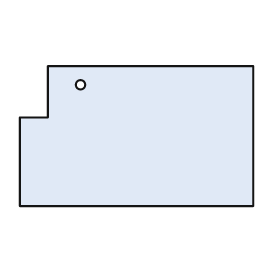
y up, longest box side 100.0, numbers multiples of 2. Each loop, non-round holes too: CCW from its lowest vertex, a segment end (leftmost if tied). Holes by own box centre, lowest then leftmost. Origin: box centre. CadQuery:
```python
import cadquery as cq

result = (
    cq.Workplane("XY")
    .moveTo(-50.0, -30.0)
    .lineTo(50.0, -30.0)
    .lineTo(50.0, 30.0)
    .lineTo(-38.0, 30.0)
    .lineTo(-38.0, 8.0)
    .lineTo(-50.0, 8.0)
    .close()
    .moveTo(-24.0, 22.0)
    .circle(2.0)
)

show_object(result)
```